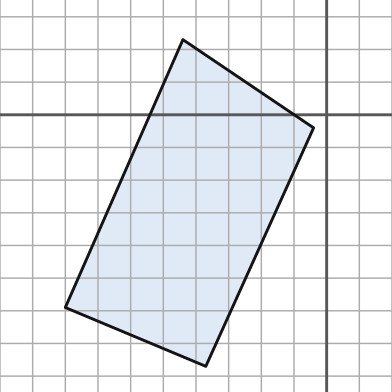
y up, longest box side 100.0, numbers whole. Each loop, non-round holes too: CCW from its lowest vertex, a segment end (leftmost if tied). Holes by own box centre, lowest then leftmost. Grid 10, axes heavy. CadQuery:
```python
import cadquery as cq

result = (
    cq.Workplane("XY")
    .moveTo(-37.0, -77.0)
    .lineTo(-4.0, -4.0)
    .lineTo(-44.0, 23.0)
    .lineTo(-80.0, -59.0)
    .close()
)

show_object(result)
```